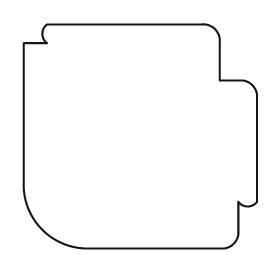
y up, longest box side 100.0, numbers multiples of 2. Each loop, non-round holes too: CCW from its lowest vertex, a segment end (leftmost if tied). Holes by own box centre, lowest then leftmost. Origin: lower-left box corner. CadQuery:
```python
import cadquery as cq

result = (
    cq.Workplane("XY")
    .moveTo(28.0, 0.0)
    .lineTo(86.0, 0.0)
    .threePointArc((90.0, 2.0), (92.0, 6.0))
    .lineTo(92.0, 20.0)
    .threePointArc((96.0, 18.0), (100.0, 20.0))
    .lineTo(100.0, 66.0)
    .threePointArc((98.0, 70.0), (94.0, 72.0))
    .lineTo(84.0, 72.0)
    .lineTo(84.0, 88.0)
    .threePointArc((82.0, 94.0), (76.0, 96.0))
    .lineTo(10.0, 96.0)
    .threePointArc((8.0, 92.0), (10.0, 88.0))
    .lineTo(0.0, 88.0)
    .lineTo(0.0, 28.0)
    .threePointArc((8.0, 8.0), (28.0, 0.0))
    .close()
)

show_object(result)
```